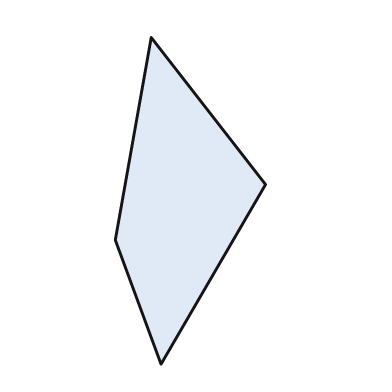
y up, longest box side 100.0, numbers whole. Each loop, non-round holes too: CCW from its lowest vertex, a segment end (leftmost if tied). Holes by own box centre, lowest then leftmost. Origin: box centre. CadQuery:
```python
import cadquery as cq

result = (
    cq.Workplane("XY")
    .moveTo(-9.0, -50.0)
    .lineTo(23.0, 5.0)
    .lineTo(-12.0, 50.0)
    .lineTo(-23.0, -12.0)
    .close()
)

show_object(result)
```